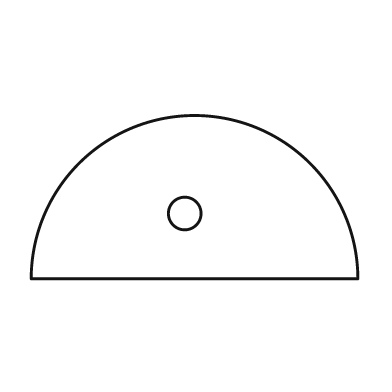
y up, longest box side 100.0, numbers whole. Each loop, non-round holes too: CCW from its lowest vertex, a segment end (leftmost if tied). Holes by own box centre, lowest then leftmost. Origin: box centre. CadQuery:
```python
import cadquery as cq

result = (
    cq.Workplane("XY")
    .moveTo(-50.0, -25.0)
    .lineTo(50.0, -25.0)
    .threePointArc((0.0, 25.0), (-50.0, -25.0))
    .close()
    .moveTo(-3.0, -5.0)
    .circle(5.0)
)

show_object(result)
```